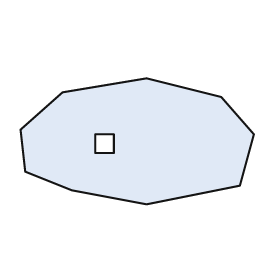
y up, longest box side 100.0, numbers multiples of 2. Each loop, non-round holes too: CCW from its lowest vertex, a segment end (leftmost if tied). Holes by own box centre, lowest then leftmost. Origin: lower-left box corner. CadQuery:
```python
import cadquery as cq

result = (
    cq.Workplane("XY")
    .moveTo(54.0, 0.0)
    .lineTo(94.0, 8.0)
    .lineTo(100.0, 30.0)
    .lineTo(86.0, 46.0)
    .lineTo(54.0, 54.0)
    .lineTo(18.0, 48.0)
    .lineTo(0.0, 32.0)
    .lineTo(2.0, 14.0)
    .lineTo(22.0, 6.0)
    .close()
    .moveTo(32.0, 22.0)
    .lineTo(40.0, 22.0)
    .lineTo(40.0, 30.0)
    .lineTo(32.0, 30.0)
    .close()
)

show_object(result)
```